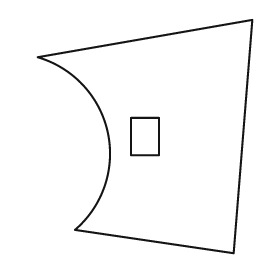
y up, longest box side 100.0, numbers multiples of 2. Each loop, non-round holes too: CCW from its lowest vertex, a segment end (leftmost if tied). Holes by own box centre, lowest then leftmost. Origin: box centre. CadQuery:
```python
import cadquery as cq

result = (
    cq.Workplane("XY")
    .moveTo(38.0, -50.0)
    .lineTo(46.0, 50.0)
    .lineTo(-46.0, 34.0)
    .threePointArc((-16.0, 2.0), (-30.0, -40.0))
    .close()
    .moveTo(-6.0, -8.0)
    .lineTo(6.0, -8.0)
    .lineTo(6.0, 8.0)
    .lineTo(-6.0, 8.0)
    .close()
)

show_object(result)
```